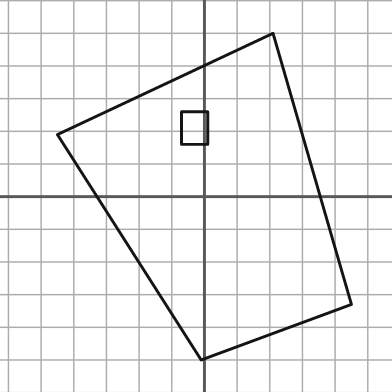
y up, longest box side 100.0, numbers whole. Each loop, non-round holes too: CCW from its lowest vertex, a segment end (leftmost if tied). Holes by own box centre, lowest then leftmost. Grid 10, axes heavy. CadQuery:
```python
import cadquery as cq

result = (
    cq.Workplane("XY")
    .moveTo(-1.0, -50.0)
    .lineTo(45.0, -33.0)
    .lineTo(21.0, 50.0)
    .lineTo(-45.0, 19.0)
    .close()
    .moveTo(-7.0, 16.0)
    .lineTo(1.0, 16.0)
    .lineTo(1.0, 26.0)
    .lineTo(-7.0, 26.0)
    .close()
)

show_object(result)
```